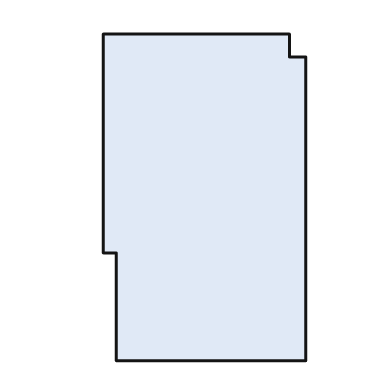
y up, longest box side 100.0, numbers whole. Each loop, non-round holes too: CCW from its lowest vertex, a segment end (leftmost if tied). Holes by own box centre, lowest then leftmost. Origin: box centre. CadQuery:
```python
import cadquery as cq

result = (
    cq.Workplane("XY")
    .moveTo(-27.0, -50.0)
    .lineTo(31.0, -50.0)
    .lineTo(31.0, 43.0)
    .lineTo(26.0, 43.0)
    .lineTo(26.0, 50.0)
    .lineTo(-31.0, 50.0)
    .lineTo(-31.0, -17.0)
    .lineTo(-27.0, -17.0)
    .close()
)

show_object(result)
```